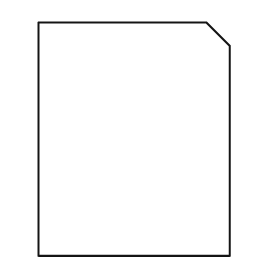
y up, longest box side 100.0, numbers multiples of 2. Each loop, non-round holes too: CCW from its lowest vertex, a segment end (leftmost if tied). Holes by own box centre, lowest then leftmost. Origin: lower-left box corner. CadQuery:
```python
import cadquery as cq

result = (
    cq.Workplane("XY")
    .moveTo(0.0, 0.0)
    .lineTo(82.0, 0.0)
    .lineTo(82.0, 90.0)
    .lineTo(72.0, 100.0)
    .lineTo(0.0, 100.0)
    .close()
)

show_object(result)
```